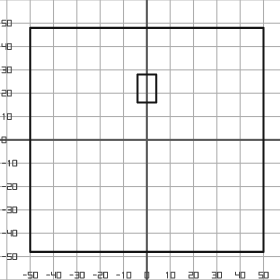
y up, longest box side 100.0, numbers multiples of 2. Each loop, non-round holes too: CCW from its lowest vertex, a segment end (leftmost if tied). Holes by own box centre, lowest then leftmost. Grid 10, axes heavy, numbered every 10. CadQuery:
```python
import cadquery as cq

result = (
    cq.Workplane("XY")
    .moveTo(-50.0, -48.0)
    .lineTo(50.0, -48.0)
    .lineTo(50.0, 48.0)
    .lineTo(-50.0, 48.0)
    .close()
    .moveTo(-4.0, 16.0)
    .lineTo(4.0, 16.0)
    .lineTo(4.0, 28.0)
    .lineTo(-4.0, 28.0)
    .close()
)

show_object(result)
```